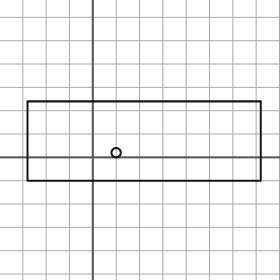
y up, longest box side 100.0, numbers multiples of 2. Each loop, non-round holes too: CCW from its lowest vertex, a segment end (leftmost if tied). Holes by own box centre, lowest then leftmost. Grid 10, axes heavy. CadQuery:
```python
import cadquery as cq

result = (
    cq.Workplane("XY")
    .moveTo(-28.0, -10.0)
    .lineTo(72.0, -10.0)
    .lineTo(72.0, 24.0)
    .lineTo(-28.0, 24.0)
    .close()
    .moveTo(10.0, 2.0)
    .circle(2.0)
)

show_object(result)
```